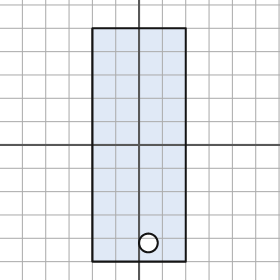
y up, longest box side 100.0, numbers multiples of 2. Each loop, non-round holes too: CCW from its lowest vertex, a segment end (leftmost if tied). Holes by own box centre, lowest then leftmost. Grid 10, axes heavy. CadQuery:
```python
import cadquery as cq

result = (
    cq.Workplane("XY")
    .moveTo(-20.0, -50.0)
    .lineTo(20.0, -50.0)
    .lineTo(20.0, 50.0)
    .lineTo(-20.0, 50.0)
    .close()
    .moveTo(4.0, -42.0)
    .circle(4.0)
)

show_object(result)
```